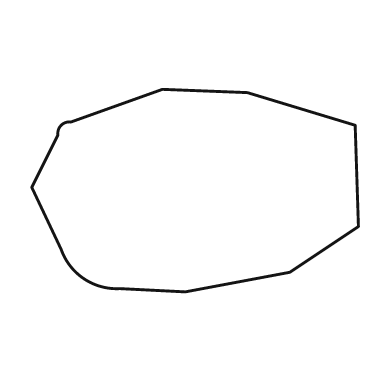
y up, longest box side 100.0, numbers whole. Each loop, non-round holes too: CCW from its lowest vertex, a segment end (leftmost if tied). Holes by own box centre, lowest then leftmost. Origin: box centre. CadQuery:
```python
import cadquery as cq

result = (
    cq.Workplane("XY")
    .moveTo(-3.0, -31.0)
    .lineTo(29.0, -25.0)
    .lineTo(50.0, -11.0)
    .lineTo(49.0, 20.0)
    .lineTo(16.0, 30.0)
    .lineTo(-10.0, 31.0)
    .lineTo(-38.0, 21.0)
    .threePointArc((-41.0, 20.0), (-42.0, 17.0))
    .lineTo(-50.0, 1.0)
    .lineTo(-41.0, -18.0)
    .threePointArc((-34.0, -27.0), (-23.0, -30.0))
    .close()
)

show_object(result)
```